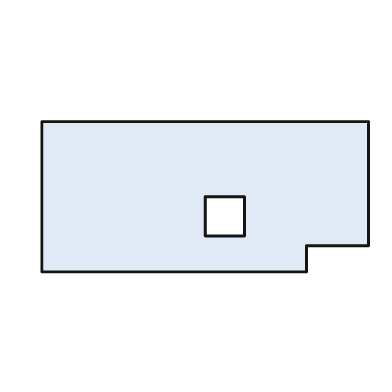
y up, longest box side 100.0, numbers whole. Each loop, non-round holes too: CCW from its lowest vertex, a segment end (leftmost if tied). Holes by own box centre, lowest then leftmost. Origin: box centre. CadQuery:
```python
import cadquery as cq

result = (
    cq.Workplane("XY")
    .moveTo(-50.0, -23.0)
    .lineTo(31.0, -23.0)
    .lineTo(31.0, -15.0)
    .lineTo(50.0, -15.0)
    .lineTo(50.0, 23.0)
    .lineTo(-50.0, 23.0)
    .close()
    .moveTo(0.0, -12.0)
    .lineTo(12.0, -12.0)
    .lineTo(12.0, 0.0)
    .lineTo(0.0, 0.0)
    .close()
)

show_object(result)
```